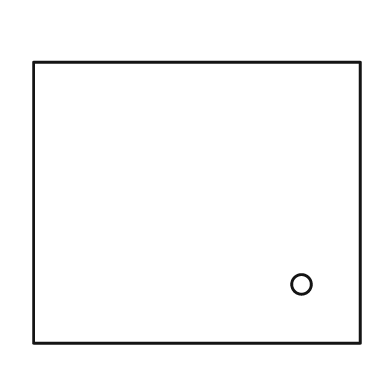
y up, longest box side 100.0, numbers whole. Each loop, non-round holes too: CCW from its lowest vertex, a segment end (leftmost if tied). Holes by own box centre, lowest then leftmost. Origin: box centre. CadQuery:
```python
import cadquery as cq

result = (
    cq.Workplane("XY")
    .moveTo(-50.0, -43.0)
    .lineTo(50.0, -43.0)
    .lineTo(50.0, 43.0)
    .lineTo(-50.0, 43.0)
    .close()
    .moveTo(32.0, -25.0)
    .circle(3.0)
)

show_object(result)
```